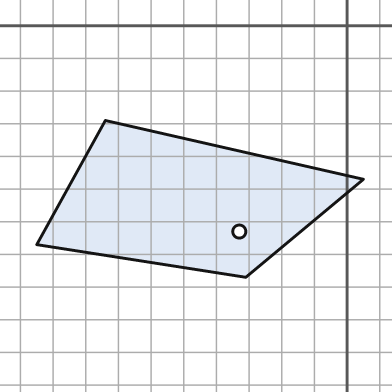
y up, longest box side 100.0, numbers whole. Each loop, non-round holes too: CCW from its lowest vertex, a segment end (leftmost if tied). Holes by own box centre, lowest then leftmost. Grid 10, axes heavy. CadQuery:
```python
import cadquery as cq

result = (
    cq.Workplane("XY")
    .moveTo(-31.0, -77.0)
    .lineTo(5.0, -47.0)
    .lineTo(-74.0, -29.0)
    .lineTo(-95.0, -67.0)
    .close()
    .moveTo(-33.0, -63.0)
    .circle(2.0)
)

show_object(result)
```